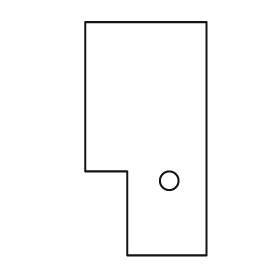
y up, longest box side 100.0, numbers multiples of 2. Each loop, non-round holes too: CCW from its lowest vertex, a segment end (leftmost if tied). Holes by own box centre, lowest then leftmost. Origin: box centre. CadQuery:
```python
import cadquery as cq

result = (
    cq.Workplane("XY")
    .moveTo(-8.0, -50.0)
    .lineTo(26.0, -50.0)
    .lineTo(26.0, 50.0)
    .lineTo(-26.0, 50.0)
    .lineTo(-26.0, -14.0)
    .lineTo(-8.0, -14.0)
    .close()
    .moveTo(10.0, -18.0)
    .circle(4.0)
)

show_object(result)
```